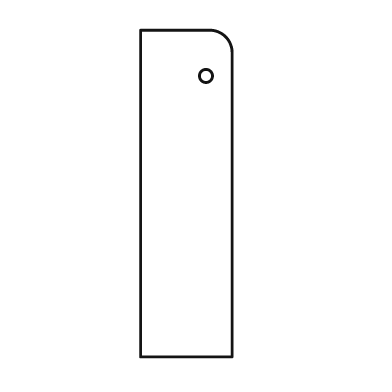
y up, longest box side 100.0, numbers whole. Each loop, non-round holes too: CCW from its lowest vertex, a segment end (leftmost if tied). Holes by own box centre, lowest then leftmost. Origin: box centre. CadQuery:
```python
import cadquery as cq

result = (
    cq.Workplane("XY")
    .moveTo(-14.0, -50.0)
    .lineTo(14.0, -50.0)
    .lineTo(14.0, 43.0)
    .threePointArc((12.0, 48.0), (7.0, 50.0))
    .lineTo(-14.0, 50.0)
    .close()
    .moveTo(6.0, 36.0)
    .circle(2.0)
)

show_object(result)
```